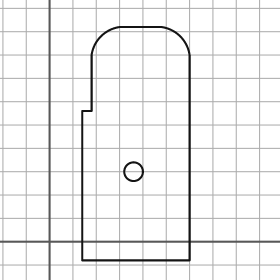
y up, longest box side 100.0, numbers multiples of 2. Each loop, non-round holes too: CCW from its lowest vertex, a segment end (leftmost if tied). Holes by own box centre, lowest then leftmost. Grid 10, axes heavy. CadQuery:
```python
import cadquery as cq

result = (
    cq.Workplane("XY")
    .moveTo(14.0, -8.0)
    .lineTo(60.0, -8.0)
    .lineTo(60.0, 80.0)
    .threePointArc((56.0, 88.0), (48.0, 92.0))
    .lineTo(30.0, 92.0)
    .threePointArc((22.0, 88.0), (18.0, 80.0))
    .lineTo(18.0, 56.0)
    .lineTo(14.0, 56.0)
    .close()
    .moveTo(36.0, 30.0)
    .circle(4.0)
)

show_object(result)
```